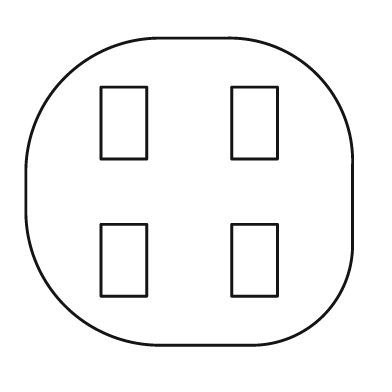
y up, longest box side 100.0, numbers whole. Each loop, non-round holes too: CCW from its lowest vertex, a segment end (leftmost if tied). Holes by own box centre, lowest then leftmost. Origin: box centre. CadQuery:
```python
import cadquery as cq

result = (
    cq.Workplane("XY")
    .moveTo(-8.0, -47.0)
    .lineTo(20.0, -47.0)
    .threePointArc((41.0, -38.0), (50.0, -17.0))
    .lineTo(50.0, 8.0)
    .threePointArc((39.0, 36.0), (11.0, 47.0))
    .lineTo(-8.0, 47.0)
    .threePointArc((-38.0, 35.0), (-50.0, 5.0))
    .lineTo(-50.0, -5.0)
    .threePointArc((-38.0, -35.0), (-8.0, -47.0))
    .close()
    .moveTo(-27.0, -32.0)
    .lineTo(-13.0, -32.0)
    .lineTo(-13.0, -10.0)
    .lineTo(-27.0, -10.0)
    .close()
    .moveTo(13.0, -32.0)
    .lineTo(27.0, -32.0)
    .lineTo(27.0, -10.0)
    .lineTo(13.0, -10.0)
    .close()
    .moveTo(-27.0, 10.0)
    .lineTo(-13.0, 10.0)
    .lineTo(-13.0, 32.0)
    .lineTo(-27.0, 32.0)
    .close()
    .moveTo(13.0, 10.0)
    .lineTo(27.0, 10.0)
    .lineTo(27.0, 32.0)
    .lineTo(13.0, 32.0)
    .close()
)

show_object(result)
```